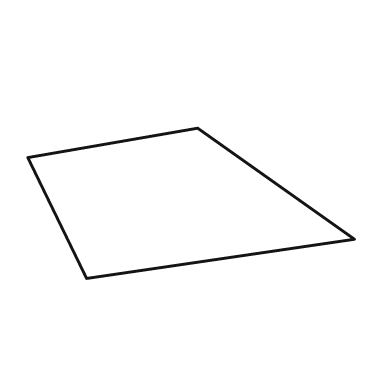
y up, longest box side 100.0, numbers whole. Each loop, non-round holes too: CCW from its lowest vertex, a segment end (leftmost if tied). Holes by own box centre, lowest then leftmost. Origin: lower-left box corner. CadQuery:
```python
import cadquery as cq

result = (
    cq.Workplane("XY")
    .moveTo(18.0, 0.0)
    .lineTo(100.0, 12.0)
    .lineTo(52.0, 46.0)
    .lineTo(0.0, 37.0)
    .close()
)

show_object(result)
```